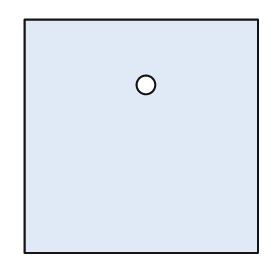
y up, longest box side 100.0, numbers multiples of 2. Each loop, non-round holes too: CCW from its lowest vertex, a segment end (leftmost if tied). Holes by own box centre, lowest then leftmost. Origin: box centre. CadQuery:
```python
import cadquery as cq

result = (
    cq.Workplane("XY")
    .moveTo(-50.0, -50.0)
    .lineTo(50.0, -50.0)
    .lineTo(50.0, 50.0)
    .lineTo(-50.0, 50.0)
    .close()
    .moveTo(2.0, 22.0)
    .circle(4.0)
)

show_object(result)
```